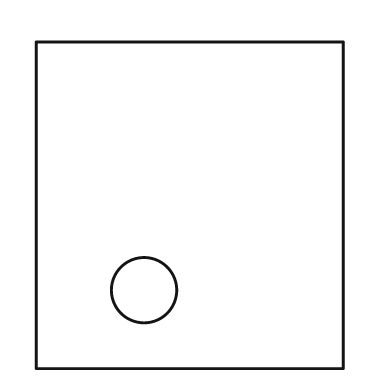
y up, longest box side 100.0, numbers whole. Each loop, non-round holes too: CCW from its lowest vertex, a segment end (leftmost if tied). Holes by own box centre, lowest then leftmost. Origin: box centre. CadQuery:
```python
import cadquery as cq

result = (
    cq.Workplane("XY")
    .moveTo(-47.0, -50.0)
    .lineTo(47.0, -50.0)
    .lineTo(47.0, 50.0)
    .lineTo(-47.0, 50.0)
    .close()
    .moveTo(-14.0, -26.0)
    .circle(10.0)
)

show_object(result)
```